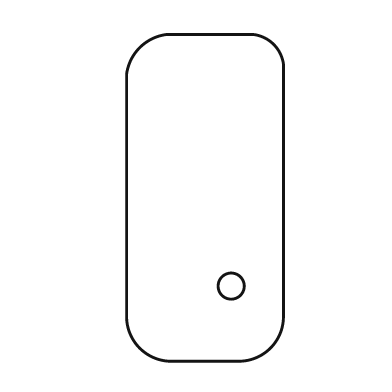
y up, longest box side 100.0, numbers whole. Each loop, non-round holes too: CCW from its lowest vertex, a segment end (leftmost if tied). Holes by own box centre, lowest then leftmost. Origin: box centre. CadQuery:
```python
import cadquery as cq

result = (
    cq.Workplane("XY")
    .moveTo(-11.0, -50.0)
    .lineTo(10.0, -50.0)
    .threePointArc((20.0, -46.0), (24.0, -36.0))
    .lineTo(24.0, 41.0)
    .threePointArc((21.0, 47.0), (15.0, 50.0))
    .lineTo(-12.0, 50.0)
    .threePointArc((-20.0, 46.0), (-24.0, 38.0))
    .lineTo(-24.0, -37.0)
    .threePointArc((-20.0, -46.0), (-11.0, -50.0))
    .close()
    .moveTo(8.0, -27.0)
    .circle(4.0)
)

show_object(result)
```